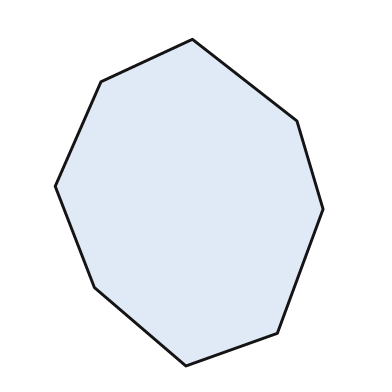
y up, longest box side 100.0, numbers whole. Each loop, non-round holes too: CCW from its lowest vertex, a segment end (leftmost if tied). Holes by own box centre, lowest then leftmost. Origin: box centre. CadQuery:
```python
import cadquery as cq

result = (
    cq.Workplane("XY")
    .moveTo(-1.0, -50.0)
    .lineTo(27.0, -40.0)
    .lineTo(41.0, -2.0)
    .lineTo(33.0, 25.0)
    .lineTo(1.0, 50.0)
    .lineTo(-27.0, 37.0)
    .lineTo(-41.0, 5.0)
    .lineTo(-29.0, -26.0)
    .close()
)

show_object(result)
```